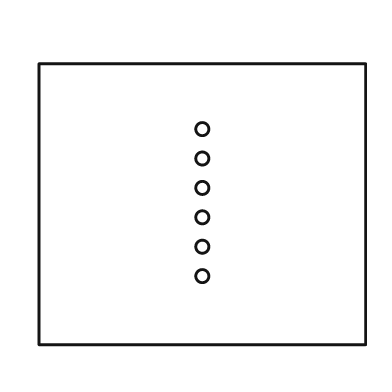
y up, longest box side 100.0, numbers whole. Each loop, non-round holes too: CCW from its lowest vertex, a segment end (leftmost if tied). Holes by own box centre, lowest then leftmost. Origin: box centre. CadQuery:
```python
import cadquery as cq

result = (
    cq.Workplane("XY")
    .moveTo(-50.0, -43.0)
    .lineTo(50.0, -43.0)
    .lineTo(50.0, 43.0)
    .lineTo(-50.0, 43.0)
    .close()
    .moveTo(0.0, -22.0)
    .circle(2.0)
    .moveTo(0.0, -13.0)
    .circle(2.0)
    .moveTo(0.0, -4.0)
    .circle(2.0)
    .moveTo(0.0, 5.0)
    .circle(2.0)
    .moveTo(0.0, 14.0)
    .circle(2.0)
    .moveTo(0.0, 23.0)
    .circle(2.0)
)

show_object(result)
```